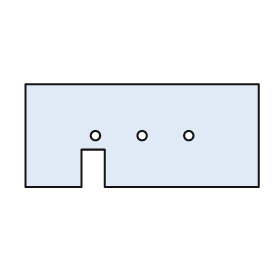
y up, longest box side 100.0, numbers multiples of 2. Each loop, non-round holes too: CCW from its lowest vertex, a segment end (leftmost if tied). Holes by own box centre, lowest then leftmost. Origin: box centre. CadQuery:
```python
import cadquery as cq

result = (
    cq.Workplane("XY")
    .moveTo(-50.0, -22.0)
    .lineTo(-26.0, -22.0)
    .lineTo(-26.0, -6.0)
    .lineTo(-16.0, -6.0)
    .lineTo(-16.0, -22.0)
    .lineTo(50.0, -22.0)
    .lineTo(50.0, 22.0)
    .lineTo(-50.0, 22.0)
    .close()
    .moveTo(-20.0, 0.0)
    .circle(2.0)
    .moveTo(0.0, 0.0)
    .circle(2.0)
    .moveTo(20.0, 0.0)
    .circle(2.0)
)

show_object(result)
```